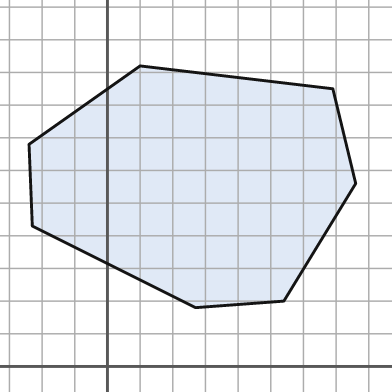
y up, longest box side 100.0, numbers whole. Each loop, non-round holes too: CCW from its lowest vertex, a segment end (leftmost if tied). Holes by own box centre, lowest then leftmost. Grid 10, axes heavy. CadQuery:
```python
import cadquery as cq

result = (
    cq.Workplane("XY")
    .moveTo(27.0, 18.0)
    .lineTo(54.0, 20.0)
    .lineTo(76.0, 56.0)
    .lineTo(69.0, 85.0)
    .lineTo(10.0, 92.0)
    .lineTo(-24.0, 68.0)
    .lineTo(-23.0, 43.0)
    .close()
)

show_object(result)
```